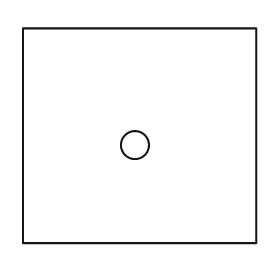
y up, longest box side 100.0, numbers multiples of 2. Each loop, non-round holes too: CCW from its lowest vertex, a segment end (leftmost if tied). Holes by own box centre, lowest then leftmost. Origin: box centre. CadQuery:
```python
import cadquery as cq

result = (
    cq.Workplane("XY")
    .moveTo(-50.0, -46.0)
    .lineTo(50.0, -46.0)
    .lineTo(50.0, 46.0)
    .lineTo(-50.0, 46.0)
    .close()
    .moveTo(-2.0, -4.0)
    .circle(6.0)
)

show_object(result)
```